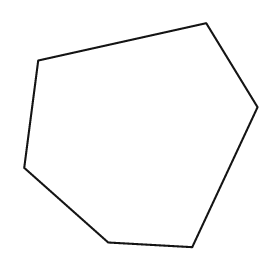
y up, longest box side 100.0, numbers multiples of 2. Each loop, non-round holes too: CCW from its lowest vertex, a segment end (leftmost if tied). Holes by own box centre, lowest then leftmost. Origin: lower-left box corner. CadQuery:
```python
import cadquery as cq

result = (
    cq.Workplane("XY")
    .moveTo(72.0, 0.0)
    .lineTo(100.0, 60.0)
    .lineTo(78.0, 96.0)
    .lineTo(6.0, 80.0)
    .lineTo(0.0, 34.0)
    .lineTo(36.0, 2.0)
    .close()
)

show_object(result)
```